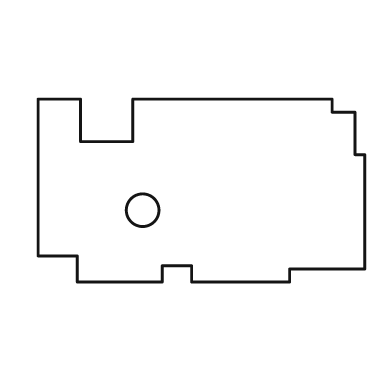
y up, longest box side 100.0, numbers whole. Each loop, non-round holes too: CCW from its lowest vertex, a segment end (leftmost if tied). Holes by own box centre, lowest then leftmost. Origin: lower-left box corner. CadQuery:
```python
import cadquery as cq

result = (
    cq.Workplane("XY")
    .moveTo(12.0, 0.0)
    .lineTo(38.0, 0.0)
    .lineTo(38.0, 5.0)
    .lineTo(47.0, 5.0)
    .lineTo(47.0, 0.0)
    .lineTo(77.0, 0.0)
    .lineTo(77.0, 4.0)
    .lineTo(100.0, 4.0)
    .lineTo(100.0, 39.0)
    .lineTo(97.0, 39.0)
    .lineTo(97.0, 52.0)
    .lineTo(90.0, 52.0)
    .lineTo(90.0, 56.0)
    .lineTo(29.0, 56.0)
    .lineTo(29.0, 43.0)
    .lineTo(13.0, 43.0)
    .lineTo(13.0, 56.0)
    .lineTo(0.0, 56.0)
    .lineTo(0.0, 8.0)
    .lineTo(12.0, 8.0)
    .close()
    .moveTo(32.0, 22.0)
    .circle(5.0)
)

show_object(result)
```